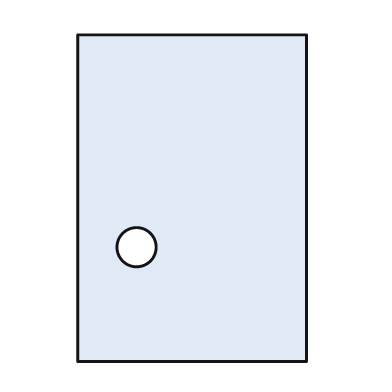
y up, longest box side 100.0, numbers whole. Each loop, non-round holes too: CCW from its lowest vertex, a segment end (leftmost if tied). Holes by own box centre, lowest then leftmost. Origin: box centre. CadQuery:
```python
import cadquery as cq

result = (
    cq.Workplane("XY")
    .moveTo(-35.0, -50.0)
    .lineTo(35.0, -50.0)
    .lineTo(35.0, 50.0)
    .lineTo(-35.0, 50.0)
    .close()
    .moveTo(-17.0, -15.0)
    .circle(6.0)
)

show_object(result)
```